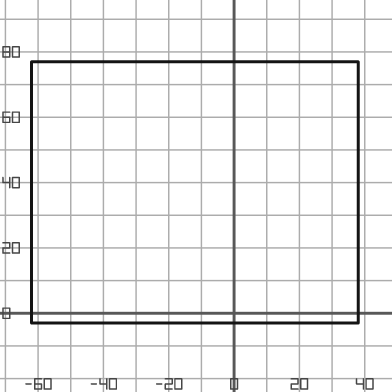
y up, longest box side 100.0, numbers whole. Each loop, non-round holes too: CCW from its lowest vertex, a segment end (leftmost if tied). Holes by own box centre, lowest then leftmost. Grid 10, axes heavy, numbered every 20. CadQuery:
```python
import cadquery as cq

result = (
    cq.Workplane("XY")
    .moveTo(-62.0, -3.0)
    .lineTo(38.0, -3.0)
    .lineTo(38.0, 77.0)
    .lineTo(-62.0, 77.0)
    .close()
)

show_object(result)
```